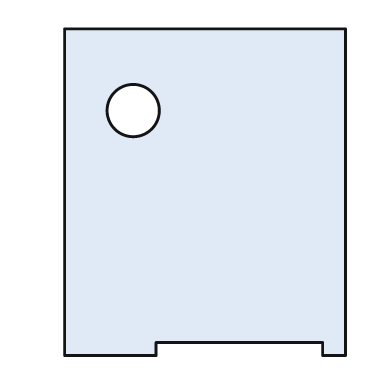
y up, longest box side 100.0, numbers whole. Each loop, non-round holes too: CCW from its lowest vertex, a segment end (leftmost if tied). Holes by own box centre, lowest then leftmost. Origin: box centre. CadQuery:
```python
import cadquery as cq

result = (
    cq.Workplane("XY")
    .moveTo(-43.0, -50.0)
    .lineTo(-15.0, -50.0)
    .lineTo(-15.0, -46.0)
    .lineTo(36.0, -46.0)
    .lineTo(36.0, -50.0)
    .lineTo(43.0, -50.0)
    .lineTo(43.0, 50.0)
    .lineTo(-43.0, 50.0)
    .close()
    .moveTo(-22.0, 25.0)
    .circle(8.0)
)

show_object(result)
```